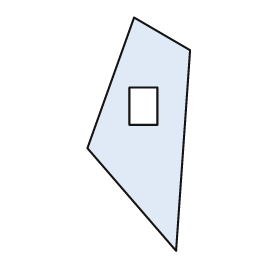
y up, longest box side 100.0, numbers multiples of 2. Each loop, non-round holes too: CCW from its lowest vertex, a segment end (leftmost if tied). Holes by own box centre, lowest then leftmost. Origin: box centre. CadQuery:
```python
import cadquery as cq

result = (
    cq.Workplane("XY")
    .moveTo(16.0, -50.0)
    .lineTo(22.0, 36.0)
    .lineTo(-2.0, 50.0)
    .lineTo(-22.0, -6.0)
    .close()
    .moveTo(-4.0, 4.0)
    .lineTo(8.0, 4.0)
    .lineTo(8.0, 20.0)
    .lineTo(-4.0, 20.0)
    .close()
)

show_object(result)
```